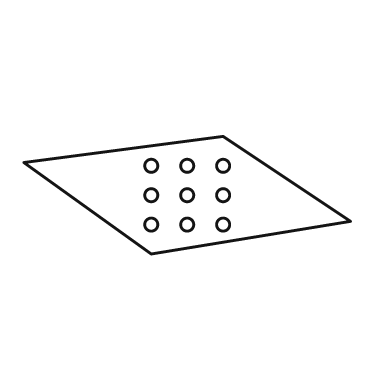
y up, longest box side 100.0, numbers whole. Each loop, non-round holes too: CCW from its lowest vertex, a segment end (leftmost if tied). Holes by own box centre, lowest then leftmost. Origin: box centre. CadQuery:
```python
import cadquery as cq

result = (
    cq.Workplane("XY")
    .moveTo(-11.0, -18.0)
    .lineTo(50.0, -8.0)
    .lineTo(11.0, 18.0)
    .lineTo(-50.0, 10.0)
    .close()
    .moveTo(-11.0, -9.0)
    .circle(2.0)
    .moveTo(0.0, -9.0)
    .circle(2.0)
    .moveTo(11.0, -9.0)
    .circle(2.0)
    .moveTo(-11.0, 0.0)
    .circle(2.0)
    .moveTo(0.0, 0.0)
    .circle(2.0)
    .moveTo(11.0, 0.0)
    .circle(2.0)
    .moveTo(-11.0, 9.0)
    .circle(2.0)
    .moveTo(0.0, 9.0)
    .circle(2.0)
    .moveTo(11.0, 9.0)
    .circle(2.0)
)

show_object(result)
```